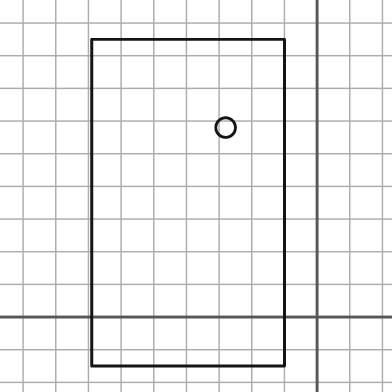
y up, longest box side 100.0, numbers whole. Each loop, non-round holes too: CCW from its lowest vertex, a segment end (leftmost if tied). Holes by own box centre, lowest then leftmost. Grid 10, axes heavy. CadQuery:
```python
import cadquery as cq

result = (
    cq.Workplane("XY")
    .moveTo(-69.0, -15.0)
    .lineTo(-10.0, -15.0)
    .lineTo(-10.0, 85.0)
    .lineTo(-69.0, 85.0)
    .close()
    .moveTo(-28.0, 58.0)
    .circle(3.0)
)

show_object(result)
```